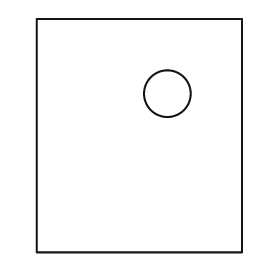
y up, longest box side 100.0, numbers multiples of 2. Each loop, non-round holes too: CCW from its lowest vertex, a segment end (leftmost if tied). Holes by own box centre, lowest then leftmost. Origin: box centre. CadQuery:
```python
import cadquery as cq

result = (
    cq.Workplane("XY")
    .moveTo(-44.0, -50.0)
    .lineTo(44.0, -50.0)
    .lineTo(44.0, 50.0)
    .lineTo(-44.0, 50.0)
    .close()
    .moveTo(12.0, 18.0)
    .circle(10.0)
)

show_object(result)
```